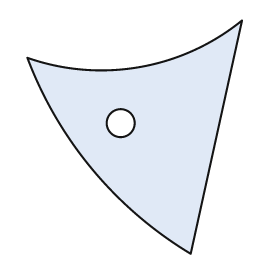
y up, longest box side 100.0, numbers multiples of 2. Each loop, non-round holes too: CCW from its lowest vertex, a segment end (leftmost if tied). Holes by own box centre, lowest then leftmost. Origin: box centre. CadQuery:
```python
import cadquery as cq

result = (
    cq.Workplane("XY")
    .moveTo(24.0, -50.0)
    .lineTo(46.0, 50.0)
    .threePointArc((2.0, 30.0), (-46.0, 34.0))
    .threePointArc((-18.0, -14.0), (24.0, -50.0))
    .close()
    .moveTo(-6.0, 6.0)
    .circle(6.0)
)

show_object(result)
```